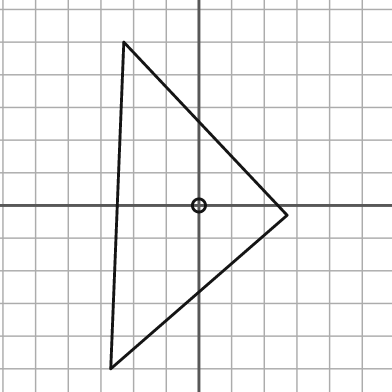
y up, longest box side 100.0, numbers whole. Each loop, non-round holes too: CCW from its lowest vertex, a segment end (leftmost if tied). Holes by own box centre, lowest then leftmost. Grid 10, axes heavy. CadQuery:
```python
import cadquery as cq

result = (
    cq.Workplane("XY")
    .moveTo(-27.0, -50.0)
    .lineTo(27.0, -3.0)
    .lineTo(-23.0, 50.0)
    .close()
    .moveTo(0.0, 0.0)
    .circle(2.0)
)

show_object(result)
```